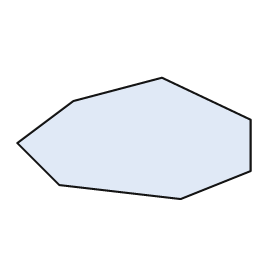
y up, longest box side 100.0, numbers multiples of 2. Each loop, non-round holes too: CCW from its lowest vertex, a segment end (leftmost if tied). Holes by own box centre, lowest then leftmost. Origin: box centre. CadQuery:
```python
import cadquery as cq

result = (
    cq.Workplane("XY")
    .moveTo(20.0, -26.0)
    .lineTo(50.0, -14.0)
    .lineTo(50.0, 8.0)
    .lineTo(12.0, 26.0)
    .lineTo(-26.0, 16.0)
    .lineTo(-50.0, -2.0)
    .lineTo(-32.0, -20.0)
    .close()
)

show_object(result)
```